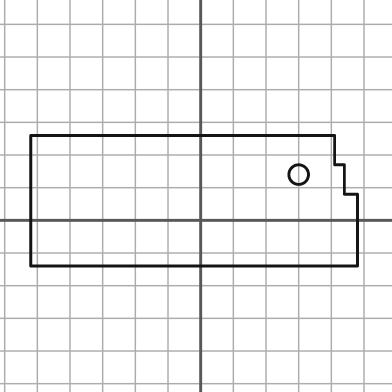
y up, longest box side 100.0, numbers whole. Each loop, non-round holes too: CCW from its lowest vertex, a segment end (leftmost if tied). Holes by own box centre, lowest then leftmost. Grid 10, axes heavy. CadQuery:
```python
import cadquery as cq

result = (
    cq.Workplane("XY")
    .moveTo(-52.0, -14.0)
    .lineTo(48.0, -14.0)
    .lineTo(48.0, 8.0)
    .lineTo(44.0, 8.0)
    .lineTo(44.0, 17.0)
    .lineTo(41.0, 17.0)
    .lineTo(41.0, 26.0)
    .lineTo(-52.0, 26.0)
    .close()
    .moveTo(30.0, 14.0)
    .circle(3.0)
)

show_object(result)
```